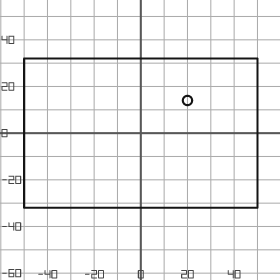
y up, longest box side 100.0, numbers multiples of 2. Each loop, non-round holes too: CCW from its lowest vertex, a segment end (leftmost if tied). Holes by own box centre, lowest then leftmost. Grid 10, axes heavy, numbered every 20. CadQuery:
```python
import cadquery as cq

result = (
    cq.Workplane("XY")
    .moveTo(-50.0, -32.0)
    .lineTo(50.0, -32.0)
    .lineTo(50.0, 32.0)
    .lineTo(-50.0, 32.0)
    .close()
    .moveTo(20.0, 14.0)
    .circle(2.0)
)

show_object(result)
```